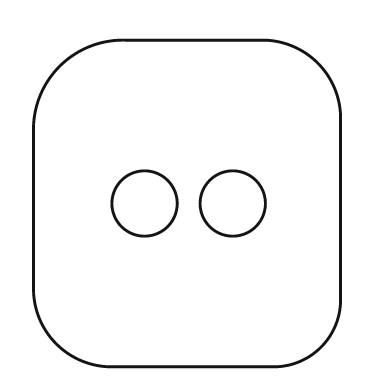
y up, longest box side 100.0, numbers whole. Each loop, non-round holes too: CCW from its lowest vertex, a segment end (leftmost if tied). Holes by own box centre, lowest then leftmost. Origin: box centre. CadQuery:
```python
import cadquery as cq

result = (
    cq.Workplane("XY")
    .moveTo(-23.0, -50.0)
    .lineTo(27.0, -50.0)
    .threePointArc((41.0, -44.0), (47.0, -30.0))
    .lineTo(47.0, 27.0)
    .threePointArc((40.0, 43.0), (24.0, 50.0))
    .lineTo(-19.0, 50.0)
    .threePointArc((-39.0, 42.0), (-47.0, 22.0))
    .lineTo(-47.0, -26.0)
    .threePointArc((-40.0, -43.0), (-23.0, -50.0))
    .close()
    .moveTo(-13.0, 0.0)
    .circle(10.0)
    .moveTo(14.0, 0.0)
    .circle(10.0)
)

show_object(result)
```